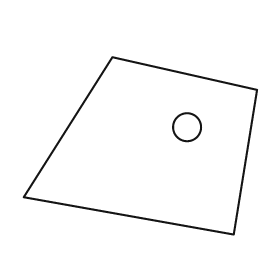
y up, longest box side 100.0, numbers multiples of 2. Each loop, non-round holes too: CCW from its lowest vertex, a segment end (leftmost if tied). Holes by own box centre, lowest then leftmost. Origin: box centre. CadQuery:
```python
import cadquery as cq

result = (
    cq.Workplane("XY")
    .moveTo(40.0, -38.0)
    .lineTo(50.0, 24.0)
    .lineTo(-12.0, 38.0)
    .lineTo(-50.0, -22.0)
    .close()
    .moveTo(20.0, 8.0)
    .circle(6.0)
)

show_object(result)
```